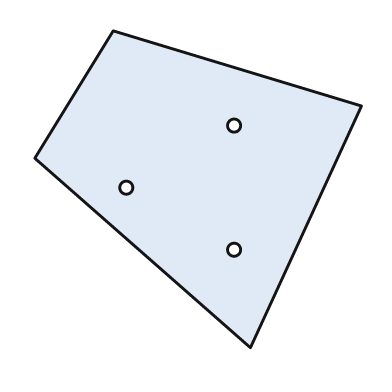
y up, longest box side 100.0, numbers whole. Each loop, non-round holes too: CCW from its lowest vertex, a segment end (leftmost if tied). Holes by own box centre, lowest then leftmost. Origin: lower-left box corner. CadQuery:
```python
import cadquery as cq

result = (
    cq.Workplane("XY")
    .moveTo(66.0, 0.0)
    .lineTo(100.0, 74.0)
    .lineTo(24.0, 97.0)
    .lineTo(0.0, 58.0)
    .close()
    .moveTo(61.0, 30.0)
    .circle(2.0)
    .moveTo(28.0, 49.0)
    .circle(2.0)
    .moveTo(61.0, 68.0)
    .circle(2.0)
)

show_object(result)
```